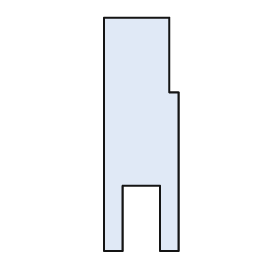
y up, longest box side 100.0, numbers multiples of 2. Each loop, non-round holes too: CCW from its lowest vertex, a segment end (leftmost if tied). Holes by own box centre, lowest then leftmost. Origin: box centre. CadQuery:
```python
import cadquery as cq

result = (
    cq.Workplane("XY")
    .moveTo(-16.0, -50.0)
    .lineTo(-8.0, -50.0)
    .lineTo(-8.0, -22.0)
    .lineTo(8.0, -22.0)
    .lineTo(8.0, -50.0)
    .lineTo(16.0, -50.0)
    .lineTo(16.0, 18.0)
    .lineTo(12.0, 18.0)
    .lineTo(12.0, 50.0)
    .lineTo(-16.0, 50.0)
    .close()
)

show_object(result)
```